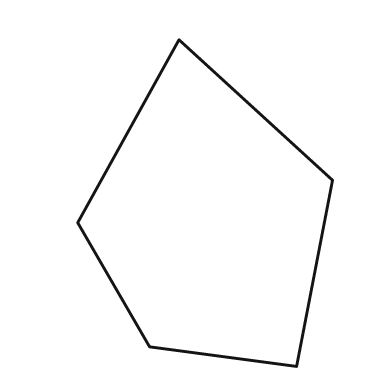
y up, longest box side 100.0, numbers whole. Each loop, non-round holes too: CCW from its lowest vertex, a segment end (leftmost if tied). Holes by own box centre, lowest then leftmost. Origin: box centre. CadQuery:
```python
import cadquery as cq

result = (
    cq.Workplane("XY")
    .moveTo(28.0, -50.0)
    .lineTo(39.0, 7.0)
    .lineTo(-8.0, 50.0)
    .lineTo(-39.0, -6.0)
    .lineTo(-17.0, -44.0)
    .close()
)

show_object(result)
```